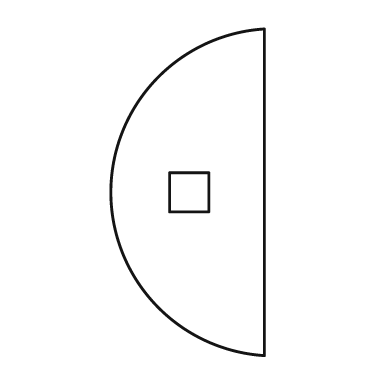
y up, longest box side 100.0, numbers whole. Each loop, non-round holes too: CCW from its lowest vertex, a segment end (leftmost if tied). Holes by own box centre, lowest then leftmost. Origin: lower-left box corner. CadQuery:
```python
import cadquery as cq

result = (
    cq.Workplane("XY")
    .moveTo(47.0, 0.0)
    .lineTo(47.0, 100.0)
    .threePointArc((0.0, 50.0), (47.0, 0.0))
    .close()
    .moveTo(18.0, 44.0)
    .lineTo(30.0, 44.0)
    .lineTo(30.0, 56.0)
    .lineTo(18.0, 56.0)
    .close()
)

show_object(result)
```